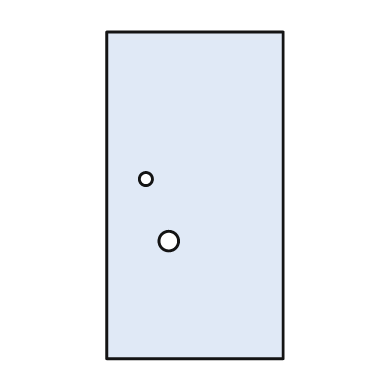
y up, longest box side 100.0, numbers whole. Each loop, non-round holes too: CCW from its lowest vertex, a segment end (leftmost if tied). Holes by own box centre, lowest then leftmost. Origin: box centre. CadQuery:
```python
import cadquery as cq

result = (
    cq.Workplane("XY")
    .moveTo(-27.0, -50.0)
    .lineTo(27.0, -50.0)
    .lineTo(27.0, 50.0)
    .lineTo(-27.0, 50.0)
    .close()
    .moveTo(-8.0, -14.0)
    .circle(3.0)
    .moveTo(-15.0, 5.0)
    .circle(2.0)
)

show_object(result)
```